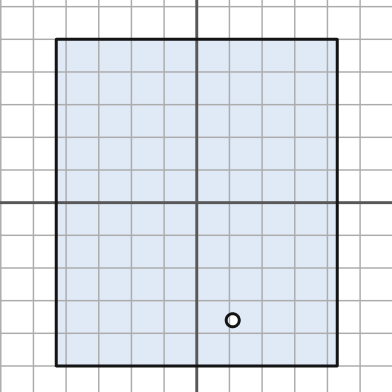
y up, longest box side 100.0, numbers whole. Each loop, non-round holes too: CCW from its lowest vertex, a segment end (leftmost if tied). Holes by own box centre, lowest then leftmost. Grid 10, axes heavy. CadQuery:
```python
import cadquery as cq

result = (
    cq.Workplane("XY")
    .moveTo(-43.0, -50.0)
    .lineTo(43.0, -50.0)
    .lineTo(43.0, 50.0)
    .lineTo(-43.0, 50.0)
    .close()
    .moveTo(11.0, -36.0)
    .circle(2.0)
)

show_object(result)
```